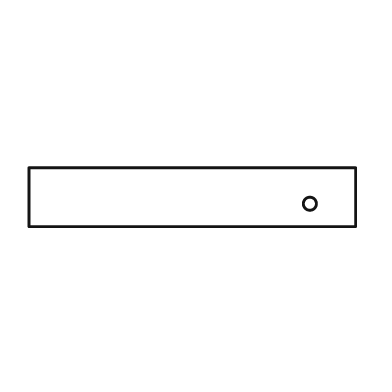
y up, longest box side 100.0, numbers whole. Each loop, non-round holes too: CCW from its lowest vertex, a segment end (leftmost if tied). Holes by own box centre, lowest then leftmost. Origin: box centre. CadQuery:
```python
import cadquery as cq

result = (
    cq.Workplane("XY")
    .moveTo(-50.0, -9.0)
    .lineTo(50.0, -9.0)
    .lineTo(50.0, 9.0)
    .lineTo(-50.0, 9.0)
    .close()
    .moveTo(36.0, -2.0)
    .circle(2.0)
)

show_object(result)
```